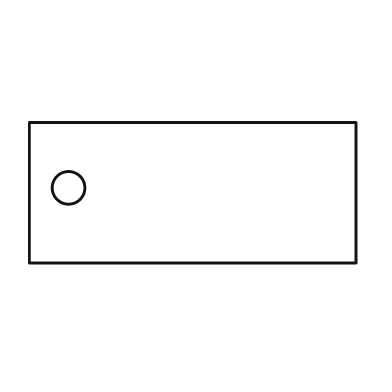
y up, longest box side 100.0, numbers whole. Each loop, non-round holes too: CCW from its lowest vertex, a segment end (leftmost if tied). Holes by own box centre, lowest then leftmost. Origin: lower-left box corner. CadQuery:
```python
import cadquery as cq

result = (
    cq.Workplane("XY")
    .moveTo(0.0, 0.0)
    .lineTo(100.0, 0.0)
    .lineTo(100.0, 43.0)
    .lineTo(0.0, 43.0)
    .close()
    .moveTo(12.0, 23.0)
    .circle(5.0)
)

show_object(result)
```